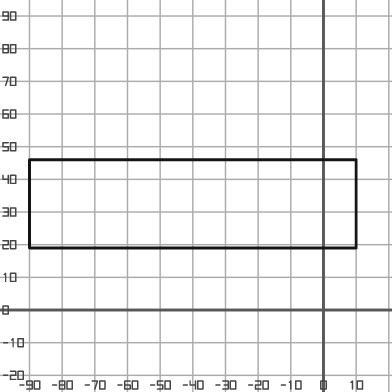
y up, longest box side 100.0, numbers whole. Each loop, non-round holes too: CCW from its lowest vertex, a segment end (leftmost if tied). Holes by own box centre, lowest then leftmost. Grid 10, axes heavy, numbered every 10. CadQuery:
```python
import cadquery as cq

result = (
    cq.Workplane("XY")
    .moveTo(-90.0, 19.0)
    .lineTo(10.0, 19.0)
    .lineTo(10.0, 46.0)
    .lineTo(-90.0, 46.0)
    .close()
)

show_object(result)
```